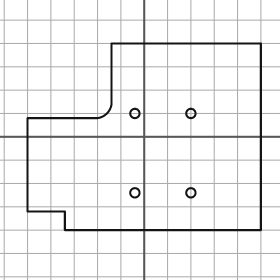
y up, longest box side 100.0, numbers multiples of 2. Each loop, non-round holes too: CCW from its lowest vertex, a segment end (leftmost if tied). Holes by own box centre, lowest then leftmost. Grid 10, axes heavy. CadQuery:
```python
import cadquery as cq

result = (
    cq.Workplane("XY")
    .moveTo(-34.0, -40.0)
    .lineTo(50.0, -40.0)
    .lineTo(50.0, 40.0)
    .lineTo(-14.0, 40.0)
    .lineTo(-14.0, 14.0)
    .threePointArc((-16.0, 10.0), (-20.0, 8.0))
    .lineTo(-50.0, 8.0)
    .lineTo(-50.0, -32.0)
    .lineTo(-34.0, -32.0)
    .close()
    .moveTo(-4.0, -24.0)
    .circle(2.0)
    .moveTo(20.0, -24.0)
    .circle(2.0)
    .moveTo(-4.0, 10.0)
    .circle(2.0)
    .moveTo(20.0, 10.0)
    .circle(2.0)
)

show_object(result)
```